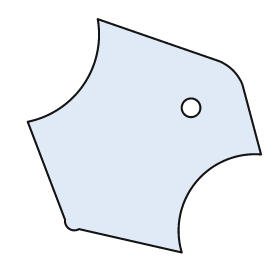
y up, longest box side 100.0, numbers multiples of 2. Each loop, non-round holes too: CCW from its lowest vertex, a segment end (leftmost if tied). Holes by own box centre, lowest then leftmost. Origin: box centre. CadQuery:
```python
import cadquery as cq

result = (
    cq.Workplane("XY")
    .moveTo(16.0, -50.0)
    .threePointArc((22.0, -20.0), (50.0, -8.0))
    .lineTo(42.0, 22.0)
    .threePointArc((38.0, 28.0), (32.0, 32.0))
    .lineTo(-20.0, 50.0)
    .threePointArc((-26.0, 22.0), (-50.0, 6.0))
    .lineTo(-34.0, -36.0)
    .threePointArc((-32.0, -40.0), (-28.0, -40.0))
    .close()
    .moveTo(20.0, 12.0)
    .circle(4.0)
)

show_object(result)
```